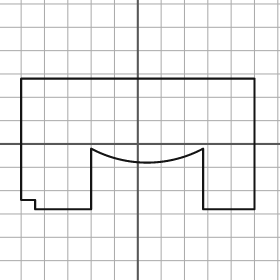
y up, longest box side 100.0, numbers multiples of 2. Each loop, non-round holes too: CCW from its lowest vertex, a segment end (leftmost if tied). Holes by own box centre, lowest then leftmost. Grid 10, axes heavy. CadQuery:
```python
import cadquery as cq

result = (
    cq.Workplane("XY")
    .moveTo(-44.0, -28.0)
    .lineTo(-20.0, -28.0)
    .lineTo(-20.0, -2.0)
    .threePointArc((4.0, -8.0), (28.0, -2.0))
    .lineTo(28.0, -28.0)
    .lineTo(50.0, -28.0)
    .lineTo(50.0, 28.0)
    .lineTo(-50.0, 28.0)
    .lineTo(-50.0, -24.0)
    .lineTo(-44.0, -24.0)
    .close()
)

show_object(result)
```